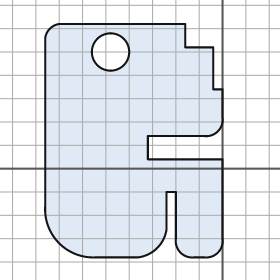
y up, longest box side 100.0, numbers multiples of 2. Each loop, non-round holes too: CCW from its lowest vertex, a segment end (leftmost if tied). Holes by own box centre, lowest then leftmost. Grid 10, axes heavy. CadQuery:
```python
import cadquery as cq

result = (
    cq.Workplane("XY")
    .moveTo(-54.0, -38.0)
    .lineTo(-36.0, -38.0)
    .threePointArc((-28.0, -34.0), (-24.0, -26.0))
    .lineTo(-24.0, -10.0)
    .lineTo(-20.0, -10.0)
    .lineTo(-20.0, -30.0)
    .threePointArc((-18.0, -36.0), (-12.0, -38.0))
    .lineTo(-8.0, -38.0)
    .threePointArc((-2.0, -36.0), (0.0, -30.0))
    .lineTo(0.0, 4.0)
    .lineTo(-32.0, 4.0)
    .lineTo(-32.0, 14.0)
    .lineTo(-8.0, 14.0)
    .threePointArc((-2.0, 16.0), (0.0, 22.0))
    .lineTo(0.0, 34.0)
    .lineTo(-4.0, 34.0)
    .lineTo(-4.0, 52.0)
    .lineTo(-16.0, 52.0)
    .lineTo(-16.0, 62.0)
    .lineTo(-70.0, 62.0)
    .threePointArc((-74.0, 60.0), (-76.0, 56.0))
    .lineTo(-76.0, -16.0)
    .threePointArc((-70.0, -32.0), (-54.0, -38.0))
    .close()
    .moveTo(-48.0, 50.0)
    .circle(8.0)
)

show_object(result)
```